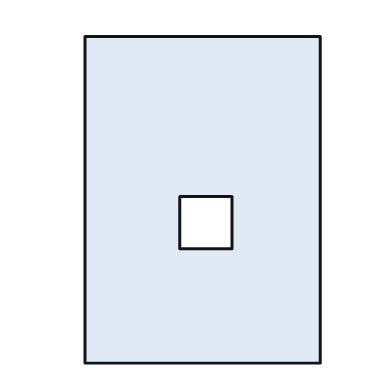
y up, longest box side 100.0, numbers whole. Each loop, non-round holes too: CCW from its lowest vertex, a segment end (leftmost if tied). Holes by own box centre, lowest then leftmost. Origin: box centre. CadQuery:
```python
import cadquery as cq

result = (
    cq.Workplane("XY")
    .moveTo(-36.0, -50.0)
    .lineTo(36.0, -50.0)
    .lineTo(36.0, 50.0)
    .lineTo(-36.0, 50.0)
    .close()
    .moveTo(-7.0, -15.0)
    .lineTo(9.0, -15.0)
    .lineTo(9.0, 1.0)
    .lineTo(-7.0, 1.0)
    .close()
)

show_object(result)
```